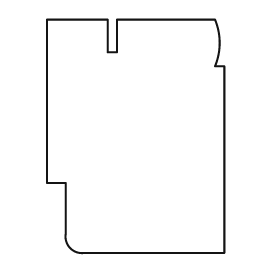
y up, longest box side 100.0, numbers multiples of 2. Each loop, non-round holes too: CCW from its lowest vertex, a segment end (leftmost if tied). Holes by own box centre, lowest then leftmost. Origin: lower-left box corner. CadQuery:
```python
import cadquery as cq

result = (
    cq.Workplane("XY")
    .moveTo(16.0, 0.0)
    .lineTo(76.0, 0.0)
    .lineTo(76.0, 80.0)
    .lineTo(72.0, 80.0)
    .threePointArc((74.0, 90.0), (72.0, 100.0))
    .lineTo(30.0, 100.0)
    .lineTo(30.0, 86.0)
    .lineTo(26.0, 86.0)
    .lineTo(26.0, 100.0)
    .lineTo(0.0, 100.0)
    .lineTo(0.0, 30.0)
    .lineTo(8.0, 30.0)
    .lineTo(8.0, 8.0)
    .threePointArc((10.0, 2.0), (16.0, 0.0))
    .close()
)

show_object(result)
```